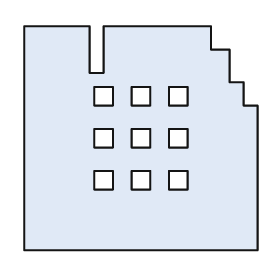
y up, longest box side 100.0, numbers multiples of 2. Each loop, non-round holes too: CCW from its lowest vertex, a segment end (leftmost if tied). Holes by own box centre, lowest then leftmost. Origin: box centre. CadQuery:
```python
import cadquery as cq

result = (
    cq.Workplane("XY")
    .moveTo(-50.0, -48.0)
    .lineTo(50.0, -48.0)
    .lineTo(50.0, 14.0)
    .lineTo(44.0, 14.0)
    .lineTo(44.0, 24.0)
    .lineTo(38.0, 24.0)
    .lineTo(38.0, 38.0)
    .lineTo(30.0, 38.0)
    .lineTo(30.0, 48.0)
    .lineTo(-16.0, 48.0)
    .lineTo(-16.0, 28.0)
    .lineTo(-22.0, 28.0)
    .lineTo(-22.0, 48.0)
    .lineTo(-50.0, 48.0)
    .close()
    .moveTo(-20.0, -22.0)
    .lineTo(-12.0, -22.0)
    .lineTo(-12.0, -14.0)
    .lineTo(-20.0, -14.0)
    .close()
    .moveTo(-4.0, -22.0)
    .lineTo(4.0, -22.0)
    .lineTo(4.0, -14.0)
    .lineTo(-4.0, -14.0)
    .close()
    .moveTo(12.0, -22.0)
    .lineTo(20.0, -22.0)
    .lineTo(20.0, -14.0)
    .lineTo(12.0, -14.0)
    .close()
    .moveTo(-20.0, -4.0)
    .lineTo(-12.0, -4.0)
    .lineTo(-12.0, 4.0)
    .lineTo(-20.0, 4.0)
    .close()
    .moveTo(-4.0, -4.0)
    .lineTo(4.0, -4.0)
    .lineTo(4.0, 4.0)
    .lineTo(-4.0, 4.0)
    .close()
    .moveTo(12.0, -4.0)
    .lineTo(20.0, -4.0)
    .lineTo(20.0, 4.0)
    .lineTo(12.0, 4.0)
    .close()
    .moveTo(-20.0, 14.0)
    .lineTo(-12.0, 14.0)
    .lineTo(-12.0, 22.0)
    .lineTo(-20.0, 22.0)
    .close()
    .moveTo(-4.0, 14.0)
    .lineTo(4.0, 14.0)
    .lineTo(4.0, 22.0)
    .lineTo(-4.0, 22.0)
    .close()
    .moveTo(12.0, 14.0)
    .lineTo(20.0, 14.0)
    .lineTo(20.0, 22.0)
    .lineTo(12.0, 22.0)
    .close()
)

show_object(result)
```